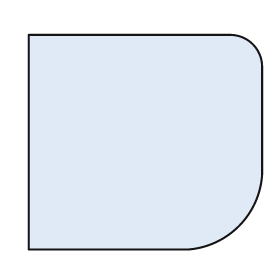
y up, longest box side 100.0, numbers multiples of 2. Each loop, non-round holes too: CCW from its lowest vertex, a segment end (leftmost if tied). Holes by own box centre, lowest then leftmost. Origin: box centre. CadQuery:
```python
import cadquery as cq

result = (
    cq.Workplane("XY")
    .moveTo(-50.0, -46.0)
    .lineTo(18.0, -46.0)
    .threePointArc((40.0, -36.0), (50.0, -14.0))
    .lineTo(50.0, 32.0)
    .threePointArc((46.0, 42.0), (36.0, 46.0))
    .lineTo(-50.0, 46.0)
    .close()
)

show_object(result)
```